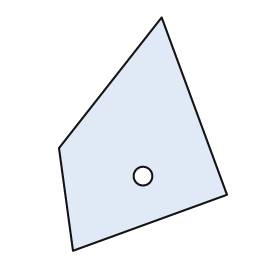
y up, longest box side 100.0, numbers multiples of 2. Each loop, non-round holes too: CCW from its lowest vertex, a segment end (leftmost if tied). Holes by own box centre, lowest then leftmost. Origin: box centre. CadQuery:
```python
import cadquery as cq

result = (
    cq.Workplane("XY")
    .moveTo(-30.0, -50.0)
    .lineTo(36.0, -26.0)
    .lineTo(8.0, 50.0)
    .lineTo(-36.0, -6.0)
    .close()
    .moveTo(0.0, -18.0)
    .circle(4.0)
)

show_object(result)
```